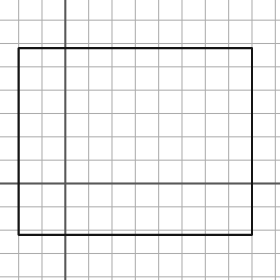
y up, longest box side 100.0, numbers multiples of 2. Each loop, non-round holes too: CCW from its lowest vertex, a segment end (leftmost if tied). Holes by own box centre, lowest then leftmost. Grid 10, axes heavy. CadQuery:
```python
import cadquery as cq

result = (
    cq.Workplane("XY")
    .moveTo(-20.0, -22.0)
    .lineTo(80.0, -22.0)
    .lineTo(80.0, 58.0)
    .lineTo(-20.0, 58.0)
    .close()
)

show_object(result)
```